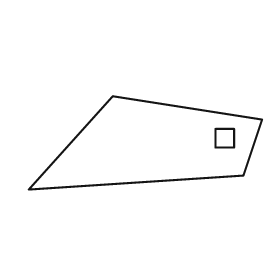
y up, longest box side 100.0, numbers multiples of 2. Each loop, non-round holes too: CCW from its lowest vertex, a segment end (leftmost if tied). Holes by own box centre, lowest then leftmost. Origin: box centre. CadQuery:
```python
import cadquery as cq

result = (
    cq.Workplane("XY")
    .moveTo(-50.0, -20.0)
    .lineTo(42.0, -14.0)
    .lineTo(50.0, 10.0)
    .lineTo(-14.0, 20.0)
    .close()
    .moveTo(30.0, -2.0)
    .lineTo(38.0, -2.0)
    .lineTo(38.0, 6.0)
    .lineTo(30.0, 6.0)
    .close()
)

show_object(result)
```